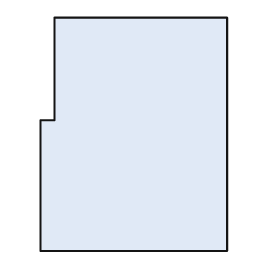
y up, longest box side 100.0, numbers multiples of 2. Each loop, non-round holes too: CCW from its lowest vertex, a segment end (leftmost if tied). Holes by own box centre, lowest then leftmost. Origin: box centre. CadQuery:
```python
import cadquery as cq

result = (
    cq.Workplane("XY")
    .moveTo(-40.0, -50.0)
    .lineTo(40.0, -50.0)
    .lineTo(40.0, 50.0)
    .lineTo(-34.0, 50.0)
    .lineTo(-34.0, 6.0)
    .lineTo(-40.0, 6.0)
    .close()
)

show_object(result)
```